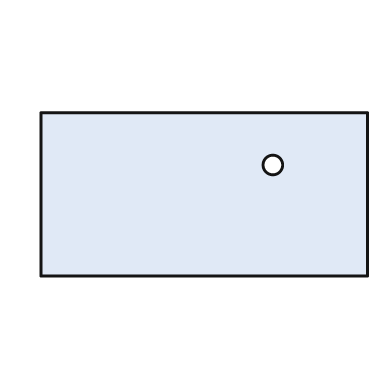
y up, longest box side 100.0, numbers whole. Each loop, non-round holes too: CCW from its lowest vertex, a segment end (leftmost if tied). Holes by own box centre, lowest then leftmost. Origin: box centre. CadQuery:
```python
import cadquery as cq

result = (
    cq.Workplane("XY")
    .moveTo(-50.0, -25.0)
    .lineTo(50.0, -25.0)
    .lineTo(50.0, 25.0)
    .lineTo(-50.0, 25.0)
    .close()
    .moveTo(21.0, 9.0)
    .circle(3.0)
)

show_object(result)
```